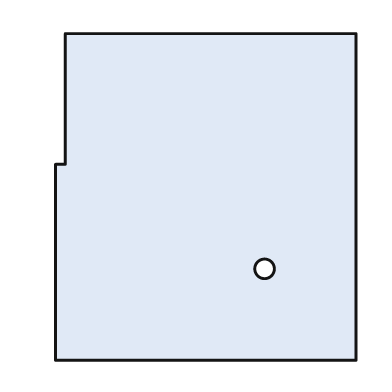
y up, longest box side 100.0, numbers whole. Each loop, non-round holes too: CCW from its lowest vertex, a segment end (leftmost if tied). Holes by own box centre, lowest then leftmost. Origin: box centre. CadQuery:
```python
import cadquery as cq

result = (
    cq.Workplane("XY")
    .moveTo(-46.0, -50.0)
    .lineTo(46.0, -50.0)
    .lineTo(46.0, 50.0)
    .lineTo(-43.0, 50.0)
    .lineTo(-43.0, 10.0)
    .lineTo(-46.0, 10.0)
    .close()
    .moveTo(18.0, -22.0)
    .circle(3.0)
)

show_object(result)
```